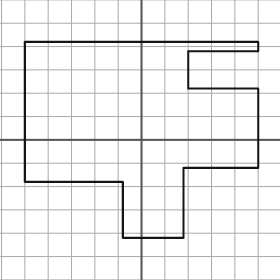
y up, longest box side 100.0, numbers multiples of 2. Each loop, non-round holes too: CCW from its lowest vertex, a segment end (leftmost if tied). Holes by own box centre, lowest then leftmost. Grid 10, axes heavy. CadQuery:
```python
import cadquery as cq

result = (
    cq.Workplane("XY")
    .moveTo(-8.0, -42.0)
    .lineTo(18.0, -42.0)
    .lineTo(18.0, -12.0)
    .lineTo(50.0, -12.0)
    .lineTo(50.0, 22.0)
    .lineTo(20.0, 22.0)
    .lineTo(20.0, 38.0)
    .lineTo(50.0, 38.0)
    .lineTo(50.0, 42.0)
    .lineTo(-50.0, 42.0)
    .lineTo(-50.0, -18.0)
    .lineTo(-8.0, -18.0)
    .close()
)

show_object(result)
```